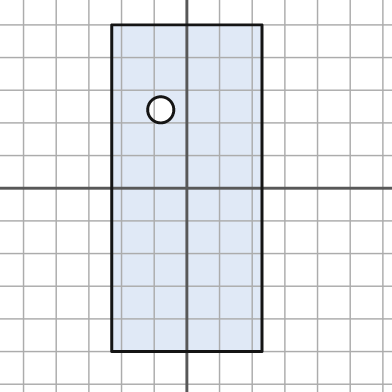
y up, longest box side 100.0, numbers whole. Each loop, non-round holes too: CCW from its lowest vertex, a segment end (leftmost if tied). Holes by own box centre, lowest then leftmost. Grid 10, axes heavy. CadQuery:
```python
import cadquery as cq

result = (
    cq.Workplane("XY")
    .moveTo(-23.0, -50.0)
    .lineTo(23.0, -50.0)
    .lineTo(23.0, 50.0)
    .lineTo(-23.0, 50.0)
    .close()
    .moveTo(-8.0, 24.0)
    .circle(4.0)
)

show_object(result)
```